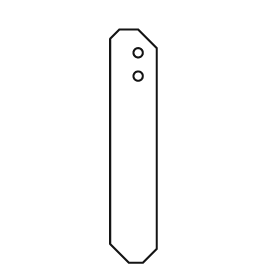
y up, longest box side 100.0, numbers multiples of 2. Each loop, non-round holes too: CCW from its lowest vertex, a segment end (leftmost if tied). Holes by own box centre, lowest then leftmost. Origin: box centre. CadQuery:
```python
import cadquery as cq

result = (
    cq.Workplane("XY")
    .moveTo(-2.0, -50.0)
    .lineTo(4.0, -50.0)
    .lineTo(10.0, -44.0)
    .lineTo(10.0, 42.0)
    .lineTo(2.0, 50.0)
    .lineTo(-6.0, 50.0)
    .lineTo(-10.0, 46.0)
    .lineTo(-10.0, -42.0)
    .close()
    .moveTo(2.0, 30.0)
    .circle(2.0)
    .moveTo(2.0, 40.0)
    .circle(2.0)
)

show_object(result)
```